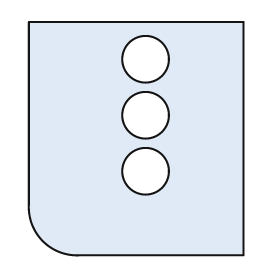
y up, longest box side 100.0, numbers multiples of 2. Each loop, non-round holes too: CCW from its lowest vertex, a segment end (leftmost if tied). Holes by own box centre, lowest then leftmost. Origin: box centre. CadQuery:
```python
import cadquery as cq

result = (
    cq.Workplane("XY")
    .moveTo(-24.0, -50.0)
    .lineTo(46.0, -50.0)
    .lineTo(46.0, 50.0)
    .lineTo(-46.0, 50.0)
    .lineTo(-46.0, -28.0)
    .threePointArc((-40.0, -44.0), (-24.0, -50.0))
    .close()
    .moveTo(4.0, -14.0)
    .circle(10.0)
    .moveTo(4.0, 10.0)
    .circle(10.0)
    .moveTo(4.0, 34.0)
    .circle(10.0)
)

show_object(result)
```